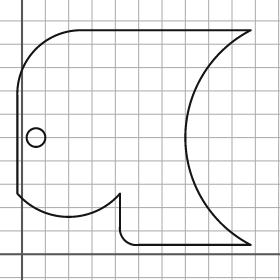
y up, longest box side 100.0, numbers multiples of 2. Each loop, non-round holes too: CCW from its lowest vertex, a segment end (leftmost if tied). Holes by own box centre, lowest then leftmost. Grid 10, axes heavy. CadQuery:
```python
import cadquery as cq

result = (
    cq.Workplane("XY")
    .moveTo(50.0, 4.0)
    .lineTo(98.0, 4.0)
    .threePointArc((70.0, 50.0), (98.0, 96.0))
    .lineTo(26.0, 96.0)
    .threePointArc((6.0, 88.0), (-2.0, 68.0))
    .lineTo(-2.0, 26.0)
    .threePointArc((20.0, 16.0), (42.0, 26.0))
    .lineTo(42.0, 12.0)
    .threePointArc((44.0, 6.0), (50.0, 4.0))
    .close()
    .moveTo(6.0, 50.0)
    .circle(4.0)
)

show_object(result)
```